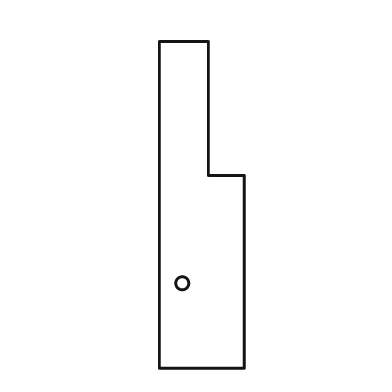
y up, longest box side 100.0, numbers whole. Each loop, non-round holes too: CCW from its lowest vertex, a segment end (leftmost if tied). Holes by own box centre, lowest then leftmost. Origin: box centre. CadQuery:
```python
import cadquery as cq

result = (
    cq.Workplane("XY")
    .moveTo(-13.0, -50.0)
    .lineTo(13.0, -50.0)
    .lineTo(13.0, 9.0)
    .lineTo(2.0, 9.0)
    .lineTo(2.0, 50.0)
    .lineTo(-13.0, 50.0)
    .close()
    .moveTo(-6.0, -24.0)
    .circle(2.0)
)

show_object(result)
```